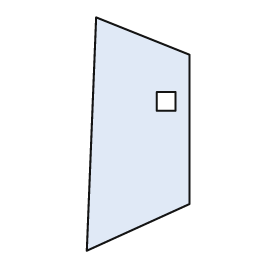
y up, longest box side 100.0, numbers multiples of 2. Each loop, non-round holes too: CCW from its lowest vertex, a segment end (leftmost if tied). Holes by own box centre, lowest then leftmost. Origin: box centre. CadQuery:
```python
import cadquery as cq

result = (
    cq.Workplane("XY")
    .moveTo(-22.0, -50.0)
    .lineTo(22.0, -30.0)
    .lineTo(22.0, 34.0)
    .lineTo(-18.0, 50.0)
    .close()
    .moveTo(8.0, 10.0)
    .lineTo(16.0, 10.0)
    .lineTo(16.0, 18.0)
    .lineTo(8.0, 18.0)
    .close()
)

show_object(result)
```